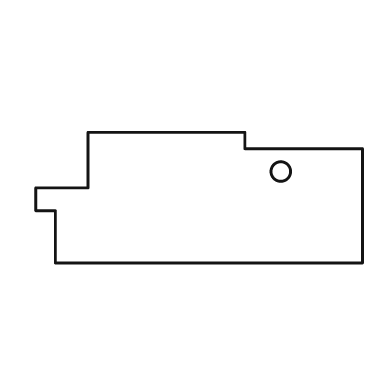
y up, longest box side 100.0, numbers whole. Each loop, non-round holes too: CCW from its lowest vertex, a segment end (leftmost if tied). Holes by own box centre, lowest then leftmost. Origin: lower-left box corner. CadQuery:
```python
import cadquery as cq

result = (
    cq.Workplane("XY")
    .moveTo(6.0, 0.0)
    .lineTo(100.0, 0.0)
    .lineTo(100.0, 35.0)
    .lineTo(64.0, 35.0)
    .lineTo(64.0, 40.0)
    .lineTo(16.0, 40.0)
    .lineTo(16.0, 23.0)
    .lineTo(0.0, 23.0)
    .lineTo(0.0, 16.0)
    .lineTo(6.0, 16.0)
    .close()
    .moveTo(75.0, 28.0)
    .circle(3.0)
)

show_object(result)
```